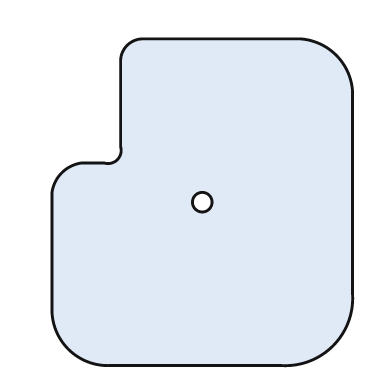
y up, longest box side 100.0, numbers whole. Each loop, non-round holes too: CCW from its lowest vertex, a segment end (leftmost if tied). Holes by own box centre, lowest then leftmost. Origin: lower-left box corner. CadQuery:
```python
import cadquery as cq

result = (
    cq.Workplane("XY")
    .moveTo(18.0, 0.0)
    .lineTo(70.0, 0.0)
    .threePointArc((86.0, 6.0), (92.0, 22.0))
    .lineTo(92.0, 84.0)
    .threePointArc((87.0, 95.0), (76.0, 100.0))
    .lineTo(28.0, 100.0)
    .threePointArc((23.0, 98.0), (21.0, 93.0))
    .lineTo(21.0, 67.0)
    .threePointArc((20.0, 63.0), (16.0, 62.0))
    .lineTo(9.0, 62.0)
    .threePointArc((3.0, 59.0), (0.0, 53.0))
    .lineTo(0.0, 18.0)
    .threePointArc((5.0, 5.0), (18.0, 0.0))
    .close()
    .moveTo(46.0, 50.0)
    .circle(3.0)
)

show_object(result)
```